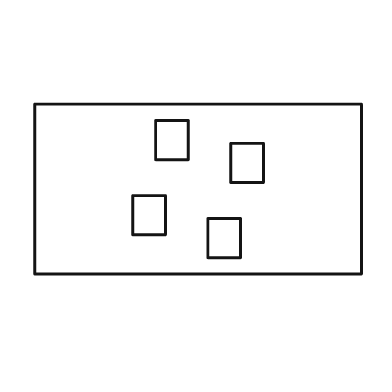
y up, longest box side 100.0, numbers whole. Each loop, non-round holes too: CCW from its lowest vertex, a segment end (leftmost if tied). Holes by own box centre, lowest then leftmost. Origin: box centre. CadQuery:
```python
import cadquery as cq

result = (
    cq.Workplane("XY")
    .moveTo(-50.0, -26.0)
    .lineTo(50.0, -26.0)
    .lineTo(50.0, 26.0)
    .lineTo(-50.0, 26.0)
    .close()
    .moveTo(3.0, -21.0)
    .lineTo(13.0, -21.0)
    .lineTo(13.0, -9.0)
    .lineTo(3.0, -9.0)
    .close()
    .moveTo(-20.0, -14.0)
    .lineTo(-10.0, -14.0)
    .lineTo(-10.0, -2.0)
    .lineTo(-20.0, -2.0)
    .close()
    .moveTo(10.0, 2.0)
    .lineTo(20.0, 2.0)
    .lineTo(20.0, 14.0)
    .lineTo(10.0, 14.0)
    .close()
    .moveTo(-13.0, 9.0)
    .lineTo(-3.0, 9.0)
    .lineTo(-3.0, 21.0)
    .lineTo(-13.0, 21.0)
    .close()
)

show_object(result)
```